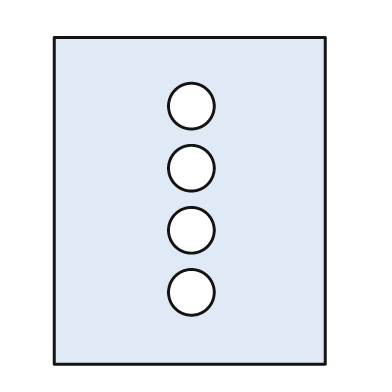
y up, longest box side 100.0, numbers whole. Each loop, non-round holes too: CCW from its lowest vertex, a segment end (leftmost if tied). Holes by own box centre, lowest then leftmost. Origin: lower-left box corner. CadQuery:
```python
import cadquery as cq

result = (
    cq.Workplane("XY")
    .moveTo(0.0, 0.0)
    .lineTo(83.0, 0.0)
    .lineTo(83.0, 100.0)
    .lineTo(0.0, 100.0)
    .close()
    .moveTo(42.0, 22.0)
    .circle(7.0)
    .moveTo(42.0, 41.0)
    .circle(7.0)
    .moveTo(42.0, 60.0)
    .circle(7.0)
    .moveTo(42.0, 79.0)
    .circle(7.0)
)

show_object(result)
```